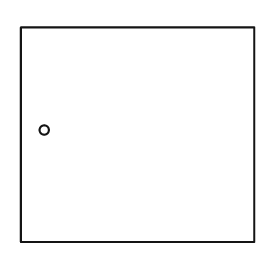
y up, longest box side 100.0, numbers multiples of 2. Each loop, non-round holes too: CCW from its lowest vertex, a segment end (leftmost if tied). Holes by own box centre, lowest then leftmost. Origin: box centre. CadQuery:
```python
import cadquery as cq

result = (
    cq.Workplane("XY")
    .moveTo(-50.0, -46.0)
    .lineTo(50.0, -46.0)
    .lineTo(50.0, 46.0)
    .lineTo(-50.0, 46.0)
    .close()
    .moveTo(-40.0, 2.0)
    .circle(2.0)
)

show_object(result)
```